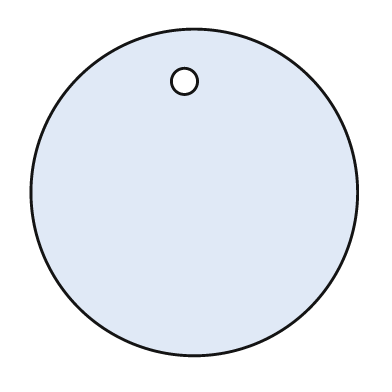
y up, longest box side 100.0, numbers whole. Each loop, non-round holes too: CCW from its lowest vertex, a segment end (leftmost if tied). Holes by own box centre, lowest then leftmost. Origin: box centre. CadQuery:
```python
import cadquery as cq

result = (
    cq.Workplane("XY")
    .moveTo(0.0, 0.0)
    .circle(50.0)
    .moveTo(-3.0, 34.0)
    .circle(4.0)
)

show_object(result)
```